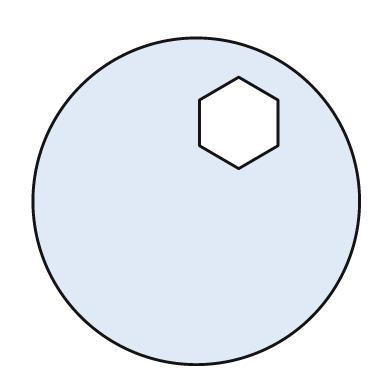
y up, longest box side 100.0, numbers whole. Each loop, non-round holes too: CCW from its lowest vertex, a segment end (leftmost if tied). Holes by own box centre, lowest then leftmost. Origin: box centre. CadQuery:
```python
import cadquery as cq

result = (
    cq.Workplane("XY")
    .moveTo(0.0, 0.0)
    .circle(50.0)
    .moveTo(13.0, 10.0)
    .lineTo(25.0, 17.0)
    .lineTo(25.0, 31.0)
    .lineTo(13.0, 38.0)
    .lineTo(1.0, 31.0)
    .lineTo(1.0, 17.0)
    .close()
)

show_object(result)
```